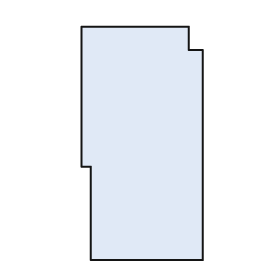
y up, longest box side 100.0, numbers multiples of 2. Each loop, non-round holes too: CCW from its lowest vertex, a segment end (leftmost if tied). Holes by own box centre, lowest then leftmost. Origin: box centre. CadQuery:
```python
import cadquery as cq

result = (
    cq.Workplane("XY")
    .moveTo(-22.0, -50.0)
    .lineTo(26.0, -50.0)
    .lineTo(26.0, 40.0)
    .lineTo(20.0, 40.0)
    .lineTo(20.0, 50.0)
    .lineTo(-26.0, 50.0)
    .lineTo(-26.0, -10.0)
    .lineTo(-22.0, -10.0)
    .close()
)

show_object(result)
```